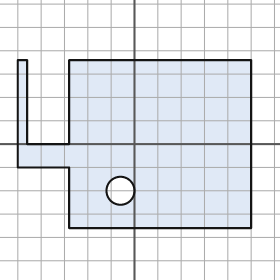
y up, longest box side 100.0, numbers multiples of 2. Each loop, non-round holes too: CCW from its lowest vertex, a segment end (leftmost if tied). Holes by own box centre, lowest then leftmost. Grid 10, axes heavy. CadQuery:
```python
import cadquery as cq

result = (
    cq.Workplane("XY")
    .moveTo(-28.0, -36.0)
    .lineTo(50.0, -36.0)
    .lineTo(50.0, 36.0)
    .lineTo(-28.0, 36.0)
    .lineTo(-28.0, 0.0)
    .lineTo(-46.0, 0.0)
    .lineTo(-46.0, 36.0)
    .lineTo(-50.0, 36.0)
    .lineTo(-50.0, -10.0)
    .lineTo(-28.0, -10.0)
    .close()
    .moveTo(-6.0, -20.0)
    .circle(6.0)
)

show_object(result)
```